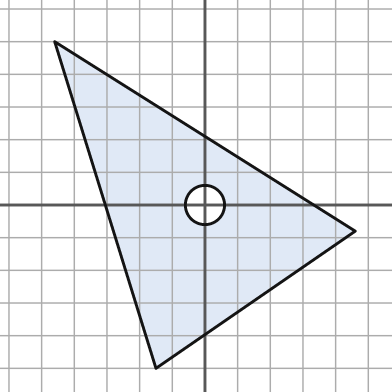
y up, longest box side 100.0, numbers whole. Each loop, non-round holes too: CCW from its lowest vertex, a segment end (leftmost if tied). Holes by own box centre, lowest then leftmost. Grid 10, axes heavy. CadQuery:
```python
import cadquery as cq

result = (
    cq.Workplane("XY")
    .moveTo(-15.0, -50.0)
    .lineTo(46.0, -8.0)
    .lineTo(-46.0, 50.0)
    .close()
    .moveTo(0.0, 0.0)
    .circle(6.0)
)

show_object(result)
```